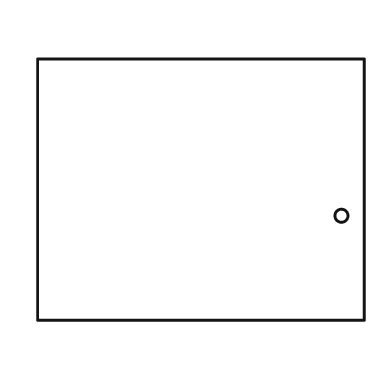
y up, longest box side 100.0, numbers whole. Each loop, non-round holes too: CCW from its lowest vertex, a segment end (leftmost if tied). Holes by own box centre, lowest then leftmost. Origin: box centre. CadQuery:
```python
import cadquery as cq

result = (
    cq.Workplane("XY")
    .moveTo(-50.0, -40.0)
    .lineTo(50.0, -40.0)
    .lineTo(50.0, 40.0)
    .lineTo(-50.0, 40.0)
    .close()
    .moveTo(43.0, -8.0)
    .circle(2.0)
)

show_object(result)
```